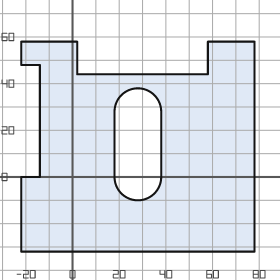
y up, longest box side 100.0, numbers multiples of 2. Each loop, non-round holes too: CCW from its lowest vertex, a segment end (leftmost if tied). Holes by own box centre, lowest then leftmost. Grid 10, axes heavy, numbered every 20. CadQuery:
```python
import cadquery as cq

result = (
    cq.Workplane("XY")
    .moveTo(-22.0, -32.0)
    .lineTo(78.0, -32.0)
    .lineTo(78.0, 58.0)
    .lineTo(58.0, 58.0)
    .lineTo(58.0, 44.0)
    .lineTo(2.0, 44.0)
    .lineTo(2.0, 58.0)
    .lineTo(-22.0, 58.0)
    .lineTo(-22.0, 48.0)
    .lineTo(-14.0, 48.0)
    .lineTo(-14.0, 0.0)
    .lineTo(-22.0, 0.0)
    .close()
    .moveTo(18.0, 0.0)
    .threePointArc((28.0, -10.0), (38.0, 0.0))
    .lineTo(38.0, 28.0)
    .threePointArc((28.0, 38.0), (18.0, 28.0))
    .close()
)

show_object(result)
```